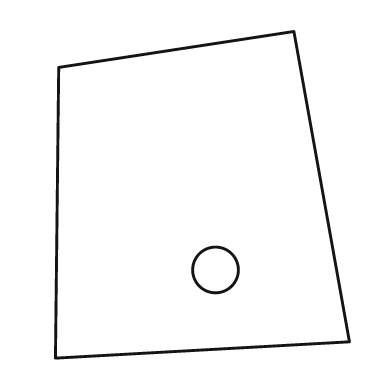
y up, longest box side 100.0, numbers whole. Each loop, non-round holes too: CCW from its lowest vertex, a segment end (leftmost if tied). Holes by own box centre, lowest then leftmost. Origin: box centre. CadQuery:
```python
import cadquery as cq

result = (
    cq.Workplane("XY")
    .moveTo(-45.0, -50.0)
    .lineTo(45.0, -45.0)
    .lineTo(28.0, 50.0)
    .lineTo(-44.0, 39.0)
    .close()
    .moveTo(4.0, -23.0)
    .circle(7.0)
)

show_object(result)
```